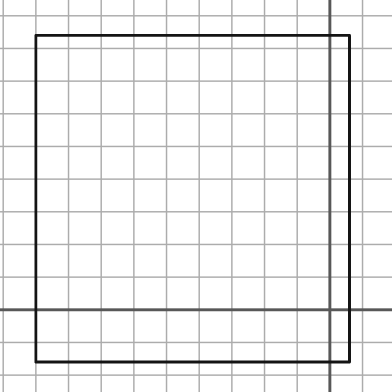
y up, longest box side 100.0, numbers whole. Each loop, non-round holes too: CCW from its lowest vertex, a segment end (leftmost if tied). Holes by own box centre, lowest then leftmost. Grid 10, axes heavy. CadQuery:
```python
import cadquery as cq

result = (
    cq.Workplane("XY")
    .moveTo(-90.0, -16.0)
    .lineTo(6.0, -16.0)
    .lineTo(6.0, 84.0)
    .lineTo(-90.0, 84.0)
    .close()
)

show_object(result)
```